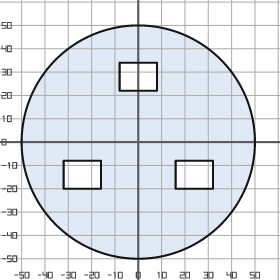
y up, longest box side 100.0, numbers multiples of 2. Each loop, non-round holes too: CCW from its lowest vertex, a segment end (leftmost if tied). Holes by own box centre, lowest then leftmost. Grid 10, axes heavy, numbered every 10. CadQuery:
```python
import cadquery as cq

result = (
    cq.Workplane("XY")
    .moveTo(0.0, 0.0)
    .circle(50.0)
    .moveTo(-32.0, -20.0)
    .lineTo(-16.0, -20.0)
    .lineTo(-16.0, -8.0)
    .lineTo(-32.0, -8.0)
    .close()
    .moveTo(16.0, -20.0)
    .lineTo(32.0, -20.0)
    .lineTo(32.0, -8.0)
    .lineTo(16.0, -8.0)
    .close()
    .moveTo(-8.0, 22.0)
    .lineTo(8.0, 22.0)
    .lineTo(8.0, 34.0)
    .lineTo(-8.0, 34.0)
    .close()
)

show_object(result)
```